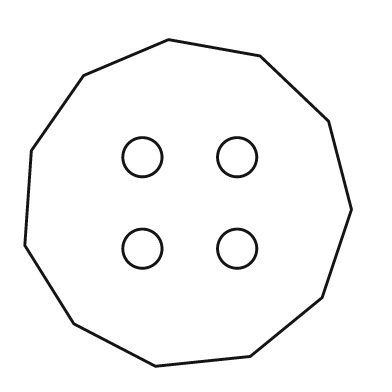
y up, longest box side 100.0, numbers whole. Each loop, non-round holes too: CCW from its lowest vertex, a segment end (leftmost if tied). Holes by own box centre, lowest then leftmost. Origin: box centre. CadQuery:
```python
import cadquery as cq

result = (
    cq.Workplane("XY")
    .moveTo(-10.0, -50.0)
    .lineTo(19.0, -47.0)
    .lineTo(41.0, -29.0)
    .lineTo(50.0, -2.0)
    .lineTo(43.0, 25.0)
    .lineTo(22.0, 45.0)
    .lineTo(-6.0, 50.0)
    .lineTo(-32.0, 39.0)
    .lineTo(-48.0, 16.0)
    .lineTo(-50.0, -13.0)
    .lineTo(-35.0, -37.0)
    .close()
    .moveTo(-14.0, -14.0)
    .circle(6.0)
    .moveTo(15.0, -14.0)
    .circle(6.0)
    .moveTo(-14.0, 14.0)
    .circle(6.0)
    .moveTo(15.0, 14.0)
    .circle(6.0)
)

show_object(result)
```